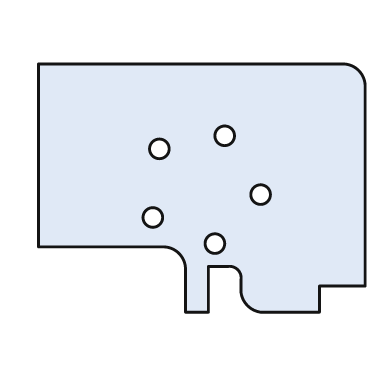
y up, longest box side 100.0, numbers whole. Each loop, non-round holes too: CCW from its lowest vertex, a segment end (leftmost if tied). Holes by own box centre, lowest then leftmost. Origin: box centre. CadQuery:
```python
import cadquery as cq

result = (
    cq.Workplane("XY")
    .moveTo(-5.0, -38.0)
    .lineTo(2.0, -38.0)
    .lineTo(2.0, -24.0)
    .lineTo(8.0, -24.0)
    .threePointArc((11.0, -25.0), (12.0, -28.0))
    .lineTo(12.0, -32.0)
    .threePointArc((14.0, -36.0), (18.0, -38.0))
    .lineTo(36.0, -38.0)
    .lineTo(36.0, -30.0)
    .lineTo(50.0, -30.0)
    .lineTo(50.0, 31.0)
    .threePointArc((48.0, 36.0), (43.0, 38.0))
    .lineTo(-50.0, 38.0)
    .lineTo(-50.0, -18.0)
    .lineTo(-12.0, -18.0)
    .threePointArc((-7.0, -20.0), (-5.0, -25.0))
    .close()
    .moveTo(4.0, -17.0)
    .circle(3.0)
    .moveTo(-15.0, -9.0)
    .circle(3.0)
    .moveTo(18.0, -2.0)
    .circle(3.0)
    .moveTo(-13.0, 12.0)
    .circle(3.0)
    .moveTo(7.0, 16.0)
    .circle(3.0)
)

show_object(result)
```